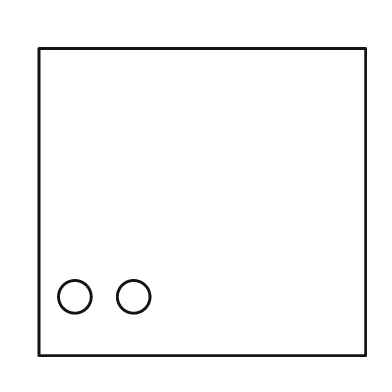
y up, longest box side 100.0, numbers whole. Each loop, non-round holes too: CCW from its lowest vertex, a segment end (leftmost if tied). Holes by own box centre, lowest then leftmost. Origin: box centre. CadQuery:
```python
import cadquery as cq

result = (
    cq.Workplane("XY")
    .moveTo(-50.0, -47.0)
    .lineTo(50.0, -47.0)
    .lineTo(50.0, 47.0)
    .lineTo(-50.0, 47.0)
    .close()
    .moveTo(-39.0, -29.0)
    .circle(5.0)
    .moveTo(-21.0, -29.0)
    .circle(5.0)
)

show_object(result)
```